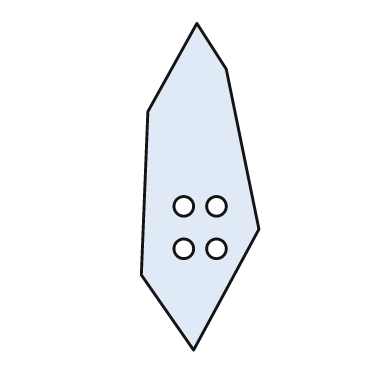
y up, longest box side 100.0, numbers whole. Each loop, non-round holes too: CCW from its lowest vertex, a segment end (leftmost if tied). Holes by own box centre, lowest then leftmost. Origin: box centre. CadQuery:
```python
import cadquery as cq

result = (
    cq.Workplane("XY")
    .moveTo(-2.0, -50.0)
    .lineTo(18.0, -13.0)
    .lineTo(8.0, 36.0)
    .lineTo(-1.0, 50.0)
    .lineTo(-16.0, 23.0)
    .lineTo(-18.0, -27.0)
    .close()
    .moveTo(-5.0, -19.0)
    .circle(3.0)
    .moveTo(5.0, -19.0)
    .circle(3.0)
    .moveTo(-5.0, -6.0)
    .circle(3.0)
    .moveTo(5.0, -6.0)
    .circle(3.0)
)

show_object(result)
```